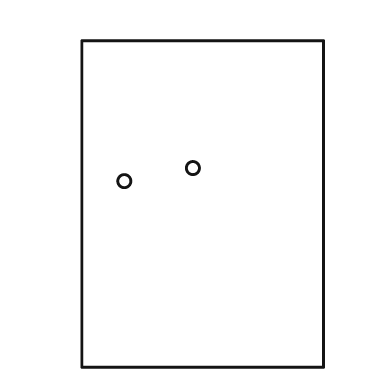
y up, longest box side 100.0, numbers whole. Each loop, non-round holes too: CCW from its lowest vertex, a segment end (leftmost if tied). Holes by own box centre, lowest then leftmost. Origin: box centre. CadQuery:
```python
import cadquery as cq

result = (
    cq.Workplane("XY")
    .moveTo(-37.0, -50.0)
    .lineTo(37.0, -50.0)
    .lineTo(37.0, 50.0)
    .lineTo(-37.0, 50.0)
    .close()
    .moveTo(-24.0, 7.0)
    .circle(2.0)
    .moveTo(-3.0, 11.0)
    .circle(2.0)
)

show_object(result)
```